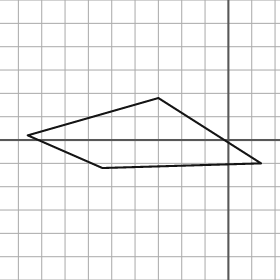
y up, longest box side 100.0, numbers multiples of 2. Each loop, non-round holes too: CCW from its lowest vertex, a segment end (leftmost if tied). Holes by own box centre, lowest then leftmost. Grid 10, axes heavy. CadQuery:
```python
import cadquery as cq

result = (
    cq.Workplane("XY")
    .moveTo(-54.0, -12.0)
    .lineTo(14.0, -10.0)
    .lineTo(-30.0, 18.0)
    .lineTo(-86.0, 2.0)
    .close()
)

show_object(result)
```